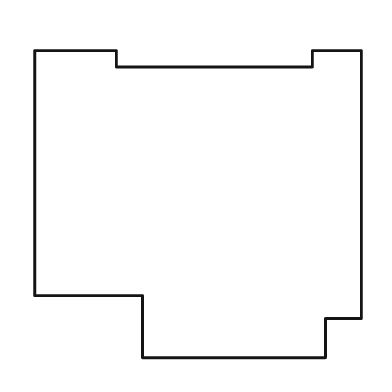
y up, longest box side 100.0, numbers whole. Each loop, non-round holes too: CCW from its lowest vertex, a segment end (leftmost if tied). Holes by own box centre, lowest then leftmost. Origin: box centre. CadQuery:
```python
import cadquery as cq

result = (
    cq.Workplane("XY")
    .moveTo(-17.0, -47.0)
    .lineTo(39.0, -47.0)
    .lineTo(39.0, -35.0)
    .lineTo(50.0, -35.0)
    .lineTo(50.0, 47.0)
    .lineTo(35.0, 47.0)
    .lineTo(35.0, 42.0)
    .lineTo(-25.0, 42.0)
    .lineTo(-25.0, 47.0)
    .lineTo(-50.0, 47.0)
    .lineTo(-50.0, -28.0)
    .lineTo(-17.0, -28.0)
    .close()
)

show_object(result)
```